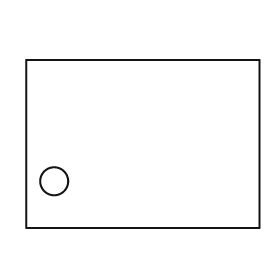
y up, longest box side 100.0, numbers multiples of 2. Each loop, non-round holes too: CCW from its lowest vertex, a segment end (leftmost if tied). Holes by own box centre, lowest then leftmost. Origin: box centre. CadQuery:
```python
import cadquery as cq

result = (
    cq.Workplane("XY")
    .moveTo(-50.0, -36.0)
    .lineTo(50.0, -36.0)
    .lineTo(50.0, 36.0)
    .lineTo(-50.0, 36.0)
    .close()
    .moveTo(-38.0, -16.0)
    .circle(6.0)
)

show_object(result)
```